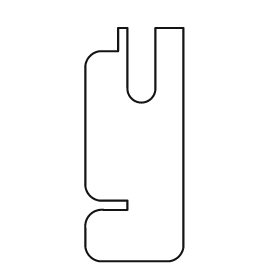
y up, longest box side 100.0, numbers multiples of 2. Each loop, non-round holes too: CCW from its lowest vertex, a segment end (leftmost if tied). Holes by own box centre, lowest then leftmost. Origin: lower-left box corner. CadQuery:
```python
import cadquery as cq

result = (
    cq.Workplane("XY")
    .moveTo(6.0, 0.0)
    .lineTo(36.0, 0.0)
    .threePointArc((40.0, 2.0), (42.0, 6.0))
    .lineTo(42.0, 100.0)
    .lineTo(30.0, 100.0)
    .lineTo(30.0, 74.0)
    .threePointArc((24.0, 68.0), (18.0, 74.0))
    .lineTo(18.0, 100.0)
    .lineTo(14.0, 100.0)
    .lineTo(14.0, 90.0)
    .lineTo(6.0, 90.0)
    .threePointArc((2.0, 88.0), (0.0, 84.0))
    .lineTo(0.0, 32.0)
    .threePointArc((2.0, 28.0), (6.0, 26.0))
    .lineTo(18.0, 26.0)
    .lineTo(18.0, 22.0)
    .lineTo(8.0, 22.0)
    .threePointArc((2.0, 20.0), (0.0, 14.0))
    .lineTo(0.0, 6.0)
    .threePointArc((2.0, 2.0), (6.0, 0.0))
    .close()
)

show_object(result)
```